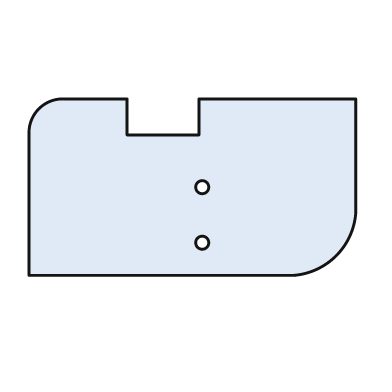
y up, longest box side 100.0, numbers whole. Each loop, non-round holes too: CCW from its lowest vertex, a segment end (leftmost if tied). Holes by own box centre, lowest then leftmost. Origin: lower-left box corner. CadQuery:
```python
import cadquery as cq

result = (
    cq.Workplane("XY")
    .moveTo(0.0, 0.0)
    .lineTo(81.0, 0.0)
    .threePointArc((94.0, 6.0), (100.0, 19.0))
    .lineTo(100.0, 54.0)
    .lineTo(52.0, 54.0)
    .lineTo(52.0, 43.0)
    .lineTo(30.0, 43.0)
    .lineTo(30.0, 54.0)
    .lineTo(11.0, 54.0)
    .threePointArc((3.0, 51.0), (0.0, 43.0))
    .close()
    .moveTo(53.0, 10.0)
    .circle(2.0)
    .moveTo(53.0, 27.0)
    .circle(2.0)
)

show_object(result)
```